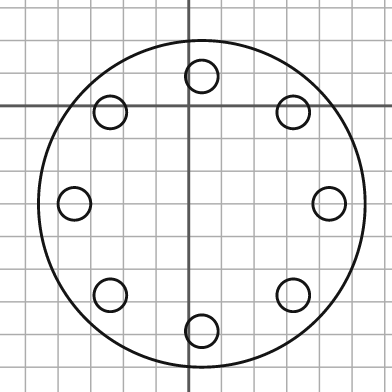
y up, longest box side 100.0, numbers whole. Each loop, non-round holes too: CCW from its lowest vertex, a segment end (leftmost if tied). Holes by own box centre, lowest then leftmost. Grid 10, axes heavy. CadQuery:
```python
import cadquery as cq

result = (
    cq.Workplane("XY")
    .moveTo(4.0, -30.0)
    .circle(50.0)
    .moveTo(4.0, -69.0)
    .circle(5.0)
    .moveTo(-24.0, -58.0)
    .circle(5.0)
    .moveTo(32.0, -58.0)
    .circle(5.0)
    .moveTo(-35.0, -30.0)
    .circle(5.0)
    .moveTo(43.0, -30.0)
    .circle(5.0)
    .moveTo(-24.0, -2.0)
    .circle(5.0)
    .moveTo(32.0, -2.0)
    .circle(5.0)
    .moveTo(4.0, 9.0)
    .circle(5.0)
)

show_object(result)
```